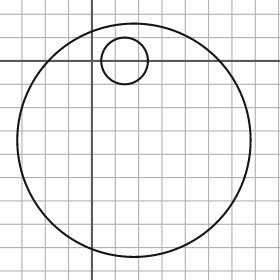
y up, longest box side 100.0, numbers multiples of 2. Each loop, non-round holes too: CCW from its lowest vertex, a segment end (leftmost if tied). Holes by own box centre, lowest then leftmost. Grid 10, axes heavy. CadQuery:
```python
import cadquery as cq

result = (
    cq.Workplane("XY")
    .moveTo(18.0, -34.0)
    .circle(50.0)
    .moveTo(14.0, 0.0)
    .circle(10.0)
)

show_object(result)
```